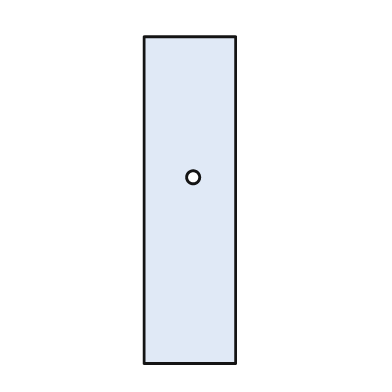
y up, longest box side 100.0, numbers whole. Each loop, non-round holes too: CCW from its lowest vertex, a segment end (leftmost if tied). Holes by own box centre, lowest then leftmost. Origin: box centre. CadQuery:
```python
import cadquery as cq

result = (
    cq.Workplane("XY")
    .moveTo(-14.0, -50.0)
    .lineTo(14.0, -50.0)
    .lineTo(14.0, 50.0)
    .lineTo(-14.0, 50.0)
    .close()
    .moveTo(1.0, 7.0)
    .circle(2.0)
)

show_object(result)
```